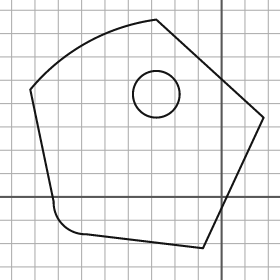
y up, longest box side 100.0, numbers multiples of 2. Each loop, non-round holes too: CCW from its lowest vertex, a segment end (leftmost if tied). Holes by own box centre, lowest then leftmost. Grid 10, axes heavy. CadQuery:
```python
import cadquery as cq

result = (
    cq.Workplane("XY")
    .moveTo(-8.0, -22.0)
    .lineTo(18.0, 34.0)
    .lineTo(-28.0, 76.0)
    .threePointArc((-58.0, 66.0), (-82.0, 46.0))
    .lineTo(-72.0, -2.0)
    .threePointArc((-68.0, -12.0), (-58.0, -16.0))
    .close()
    .moveTo(-28.0, 44.0)
    .circle(10.0)
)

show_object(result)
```